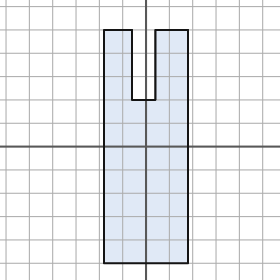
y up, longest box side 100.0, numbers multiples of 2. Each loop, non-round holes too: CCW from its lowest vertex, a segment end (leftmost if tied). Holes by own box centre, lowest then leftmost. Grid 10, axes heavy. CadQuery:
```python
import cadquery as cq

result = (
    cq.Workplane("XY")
    .moveTo(-18.0, -50.0)
    .lineTo(18.0, -50.0)
    .lineTo(18.0, 50.0)
    .lineTo(4.0, 50.0)
    .lineTo(4.0, 20.0)
    .lineTo(-6.0, 20.0)
    .lineTo(-6.0, 50.0)
    .lineTo(-18.0, 50.0)
    .close()
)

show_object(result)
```